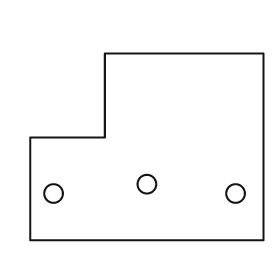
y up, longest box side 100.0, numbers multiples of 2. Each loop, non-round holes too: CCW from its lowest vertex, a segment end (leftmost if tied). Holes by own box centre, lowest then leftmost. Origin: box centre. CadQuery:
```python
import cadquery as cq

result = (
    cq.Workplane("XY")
    .moveTo(-50.0, -40.0)
    .lineTo(50.0, -40.0)
    .lineTo(50.0, 40.0)
    .lineTo(-18.0, 40.0)
    .lineTo(-18.0, 4.0)
    .lineTo(-50.0, 4.0)
    .close()
    .moveTo(-40.0, -20.0)
    .circle(4.0)
    .moveTo(38.0, -20.0)
    .circle(4.0)
    .moveTo(0.0, -16.0)
    .circle(4.0)
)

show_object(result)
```